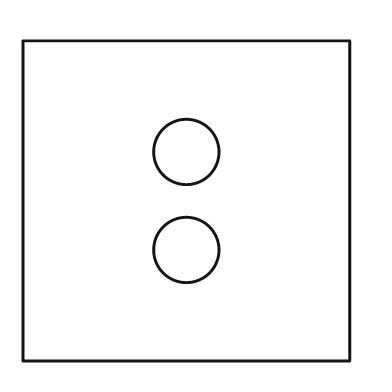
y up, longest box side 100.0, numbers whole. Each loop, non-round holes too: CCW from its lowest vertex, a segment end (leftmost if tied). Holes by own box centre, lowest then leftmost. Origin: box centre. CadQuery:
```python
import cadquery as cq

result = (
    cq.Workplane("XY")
    .moveTo(-50.0, -49.0)
    .lineTo(50.0, -49.0)
    .lineTo(50.0, 49.0)
    .lineTo(-50.0, 49.0)
    .close()
    .moveTo(0.0, -15.0)
    .circle(10.0)
    .moveTo(0.0, 15.0)
    .circle(10.0)
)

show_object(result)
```